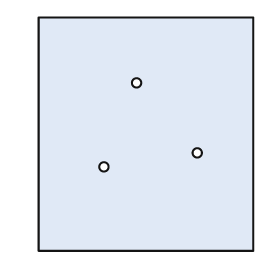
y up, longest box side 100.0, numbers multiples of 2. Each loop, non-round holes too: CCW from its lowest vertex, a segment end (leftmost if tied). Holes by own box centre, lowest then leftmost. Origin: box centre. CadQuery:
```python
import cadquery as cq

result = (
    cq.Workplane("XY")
    .moveTo(-46.0, -50.0)
    .lineTo(46.0, -50.0)
    .lineTo(46.0, 50.0)
    .lineTo(-46.0, 50.0)
    .close()
    .moveTo(-18.0, -14.0)
    .circle(2.0)
    .moveTo(22.0, -8.0)
    .circle(2.0)
    .moveTo(-4.0, 22.0)
    .circle(2.0)
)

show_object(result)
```